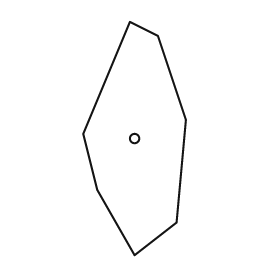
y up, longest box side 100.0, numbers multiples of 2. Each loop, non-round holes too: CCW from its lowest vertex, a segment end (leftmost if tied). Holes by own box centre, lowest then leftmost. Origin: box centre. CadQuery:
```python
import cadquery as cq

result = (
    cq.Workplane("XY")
    .moveTo(0.0, -50.0)
    .lineTo(18.0, -36.0)
    .lineTo(22.0, 8.0)
    .lineTo(10.0, 44.0)
    .lineTo(-2.0, 50.0)
    .lineTo(-22.0, 2.0)
    .lineTo(-16.0, -22.0)
    .close()
    .moveTo(0.0, 0.0)
    .circle(2.0)
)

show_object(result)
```